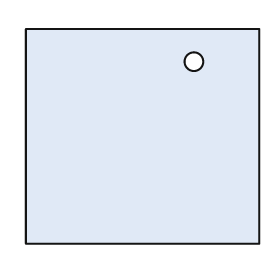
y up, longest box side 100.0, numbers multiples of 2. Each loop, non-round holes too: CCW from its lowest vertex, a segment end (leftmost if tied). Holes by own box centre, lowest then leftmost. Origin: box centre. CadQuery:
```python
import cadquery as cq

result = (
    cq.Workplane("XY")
    .moveTo(-50.0, -46.0)
    .lineTo(50.0, -46.0)
    .lineTo(50.0, 46.0)
    .lineTo(-50.0, 46.0)
    .close()
    .moveTo(22.0, 32.0)
    .circle(4.0)
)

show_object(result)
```